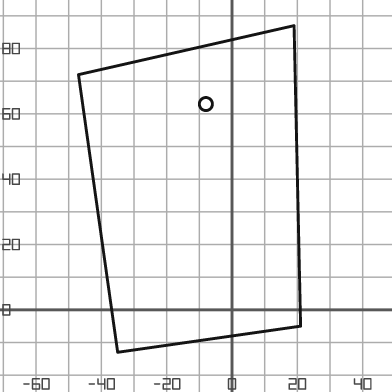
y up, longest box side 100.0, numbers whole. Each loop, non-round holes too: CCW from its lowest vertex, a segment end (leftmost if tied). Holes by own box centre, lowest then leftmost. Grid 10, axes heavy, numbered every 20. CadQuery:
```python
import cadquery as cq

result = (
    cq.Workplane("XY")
    .moveTo(-35.0, -13.0)
    .lineTo(21.0, -5.0)
    .lineTo(19.0, 87.0)
    .lineTo(-47.0, 72.0)
    .close()
    .moveTo(-8.0, 63.0)
    .circle(2.0)
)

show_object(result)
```